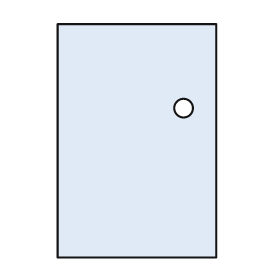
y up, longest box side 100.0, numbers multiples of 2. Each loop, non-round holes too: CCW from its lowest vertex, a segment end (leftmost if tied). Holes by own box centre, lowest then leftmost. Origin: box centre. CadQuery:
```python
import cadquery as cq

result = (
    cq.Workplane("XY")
    .moveTo(-34.0, -50.0)
    .lineTo(34.0, -50.0)
    .lineTo(34.0, 50.0)
    .lineTo(-34.0, 50.0)
    .close()
    .moveTo(20.0, 14.0)
    .circle(4.0)
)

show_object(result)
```